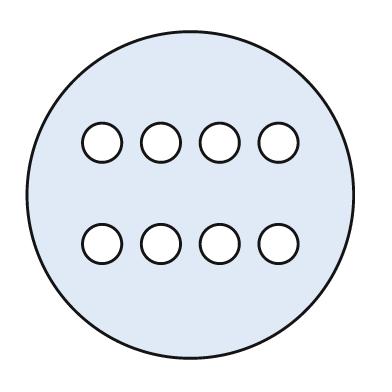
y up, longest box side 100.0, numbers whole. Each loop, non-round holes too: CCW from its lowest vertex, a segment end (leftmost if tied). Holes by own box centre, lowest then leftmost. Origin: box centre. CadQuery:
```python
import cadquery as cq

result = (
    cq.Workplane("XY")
    .moveTo(0.0, 0.0)
    .circle(50.0)
    .moveTo(-27.0, -15.0)
    .circle(6.0)
    .moveTo(-9.0, -15.0)
    .circle(6.0)
    .moveTo(9.0, -15.0)
    .circle(6.0)
    .moveTo(27.0, -15.0)
    .circle(6.0)
    .moveTo(-27.0, 16.0)
    .circle(6.0)
    .moveTo(-9.0, 16.0)
    .circle(6.0)
    .moveTo(9.0, 16.0)
    .circle(6.0)
    .moveTo(27.0, 16.0)
    .circle(6.0)
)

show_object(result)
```